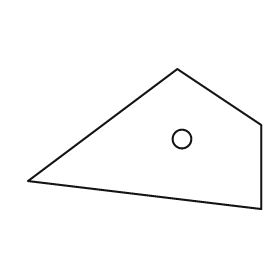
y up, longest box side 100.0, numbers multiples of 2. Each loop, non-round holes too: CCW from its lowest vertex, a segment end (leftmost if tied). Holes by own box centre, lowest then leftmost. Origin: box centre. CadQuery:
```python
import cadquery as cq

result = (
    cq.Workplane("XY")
    .moveTo(50.0, -30.0)
    .lineTo(50.0, 6.0)
    .lineTo(14.0, 30.0)
    .lineTo(-50.0, -18.0)
    .close()
    .moveTo(16.0, 0.0)
    .circle(4.0)
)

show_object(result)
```